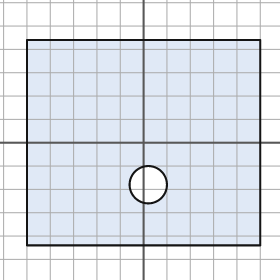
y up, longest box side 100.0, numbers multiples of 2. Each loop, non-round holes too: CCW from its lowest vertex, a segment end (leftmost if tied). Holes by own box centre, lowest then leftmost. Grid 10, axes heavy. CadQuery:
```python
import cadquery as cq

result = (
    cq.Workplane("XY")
    .moveTo(-50.0, -44.0)
    .lineTo(50.0, -44.0)
    .lineTo(50.0, 44.0)
    .lineTo(-50.0, 44.0)
    .close()
    .moveTo(2.0, -18.0)
    .circle(8.0)
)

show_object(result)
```